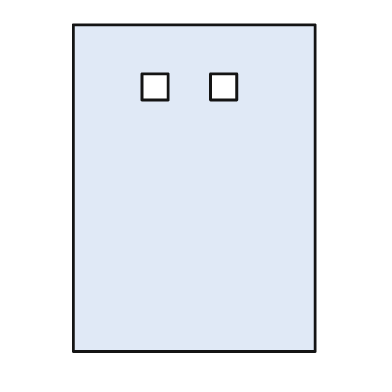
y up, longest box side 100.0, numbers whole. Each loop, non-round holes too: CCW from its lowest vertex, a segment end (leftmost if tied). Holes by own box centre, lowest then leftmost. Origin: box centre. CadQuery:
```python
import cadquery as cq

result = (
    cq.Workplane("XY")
    .moveTo(-37.0, -50.0)
    .lineTo(37.0, -50.0)
    .lineTo(37.0, 50.0)
    .lineTo(-37.0, 50.0)
    .close()
    .moveTo(-16.0, 27.0)
    .lineTo(-8.0, 27.0)
    .lineTo(-8.0, 35.0)
    .lineTo(-16.0, 35.0)
    .close()
    .moveTo(5.0, 27.0)
    .lineTo(13.0, 27.0)
    .lineTo(13.0, 35.0)
    .lineTo(5.0, 35.0)
    .close()
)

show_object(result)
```